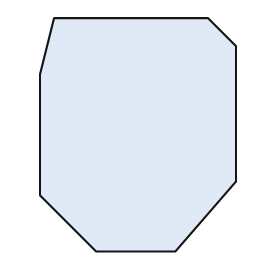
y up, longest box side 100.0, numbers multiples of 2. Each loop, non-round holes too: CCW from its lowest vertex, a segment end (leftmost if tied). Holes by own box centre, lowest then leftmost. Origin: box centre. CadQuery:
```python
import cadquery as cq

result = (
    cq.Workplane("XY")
    .moveTo(-18.0, -50.0)
    .lineTo(16.0, -50.0)
    .lineTo(42.0, -20.0)
    .lineTo(42.0, 38.0)
    .lineTo(30.0, 50.0)
    .lineTo(-36.0, 50.0)
    .lineTo(-42.0, 26.0)
    .lineTo(-42.0, -26.0)
    .close()
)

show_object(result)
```